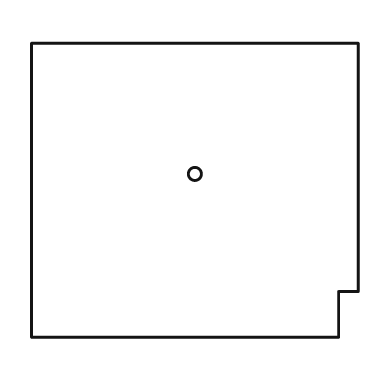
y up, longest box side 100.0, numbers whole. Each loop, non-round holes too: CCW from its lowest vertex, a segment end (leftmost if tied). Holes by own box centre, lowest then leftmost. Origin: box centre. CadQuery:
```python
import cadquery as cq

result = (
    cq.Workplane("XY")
    .moveTo(-50.0, -45.0)
    .lineTo(44.0, -45.0)
    .lineTo(44.0, -31.0)
    .lineTo(50.0, -31.0)
    .lineTo(50.0, 45.0)
    .lineTo(-50.0, 45.0)
    .close()
    .moveTo(0.0, 5.0)
    .circle(2.0)
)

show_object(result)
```